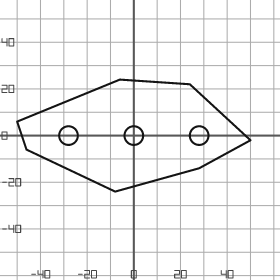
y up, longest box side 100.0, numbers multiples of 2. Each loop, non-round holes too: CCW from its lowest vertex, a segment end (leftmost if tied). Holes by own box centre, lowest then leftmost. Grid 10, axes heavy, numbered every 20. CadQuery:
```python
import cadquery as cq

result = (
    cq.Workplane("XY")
    .moveTo(-8.0, -24.0)
    .lineTo(28.0, -14.0)
    .lineTo(50.0, -2.0)
    .lineTo(24.0, 22.0)
    .lineTo(-6.0, 24.0)
    .lineTo(-50.0, 6.0)
    .lineTo(-46.0, -6.0)
    .close()
    .moveTo(-28.0, 0.0)
    .circle(4.0)
    .moveTo(0.0, 0.0)
    .circle(4.0)
    .moveTo(28.0, 0.0)
    .circle(4.0)
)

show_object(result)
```